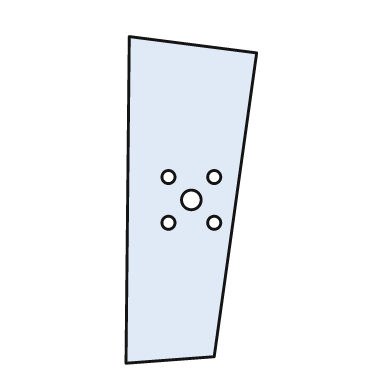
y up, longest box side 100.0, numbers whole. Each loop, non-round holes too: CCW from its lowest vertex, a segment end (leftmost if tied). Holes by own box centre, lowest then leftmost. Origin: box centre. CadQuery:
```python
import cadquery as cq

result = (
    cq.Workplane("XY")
    .moveTo(-20.0, -50.0)
    .lineTo(7.0, -48.0)
    .lineTo(20.0, 45.0)
    .lineTo(-19.0, 50.0)
    .close()
    .moveTo(-7.0, -7.0)
    .circle(2.0)
    .moveTo(7.0, -7.0)
    .circle(2.0)
    .moveTo(0.0, 0.0)
    .circle(3.0)
    .moveTo(-7.0, 7.0)
    .circle(2.0)
    .moveTo(7.0, 7.0)
    .circle(2.0)
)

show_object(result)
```